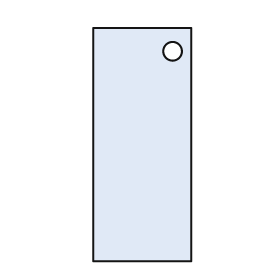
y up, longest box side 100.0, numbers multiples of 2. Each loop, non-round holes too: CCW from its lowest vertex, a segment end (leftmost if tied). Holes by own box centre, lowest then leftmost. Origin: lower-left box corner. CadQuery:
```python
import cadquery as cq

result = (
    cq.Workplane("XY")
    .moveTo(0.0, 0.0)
    .lineTo(42.0, 0.0)
    .lineTo(42.0, 100.0)
    .lineTo(0.0, 100.0)
    .close()
    .moveTo(34.0, 90.0)
    .circle(4.0)
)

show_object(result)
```